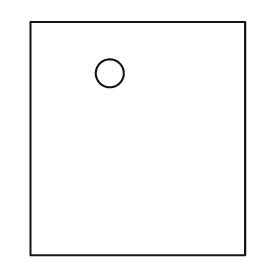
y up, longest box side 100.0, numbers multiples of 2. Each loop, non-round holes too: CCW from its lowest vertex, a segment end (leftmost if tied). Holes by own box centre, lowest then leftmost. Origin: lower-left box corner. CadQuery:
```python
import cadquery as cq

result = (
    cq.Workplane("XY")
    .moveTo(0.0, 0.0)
    .lineTo(92.0, 0.0)
    .lineTo(92.0, 100.0)
    .lineTo(0.0, 100.0)
    .close()
    .moveTo(34.0, 78.0)
    .circle(6.0)
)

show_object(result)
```